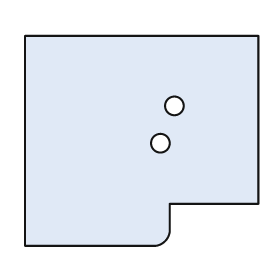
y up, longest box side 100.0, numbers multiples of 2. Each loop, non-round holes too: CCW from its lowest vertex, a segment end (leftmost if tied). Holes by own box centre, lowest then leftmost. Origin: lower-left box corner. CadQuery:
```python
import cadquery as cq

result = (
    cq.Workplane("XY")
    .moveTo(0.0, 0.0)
    .lineTo(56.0, 0.0)
    .threePointArc((60.0, 2.0), (62.0, 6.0))
    .lineTo(62.0, 18.0)
    .lineTo(100.0, 18.0)
    .lineTo(100.0, 90.0)
    .lineTo(0.0, 90.0)
    .close()
    .moveTo(58.0, 44.0)
    .circle(4.0)
    .moveTo(64.0, 60.0)
    .circle(4.0)
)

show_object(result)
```